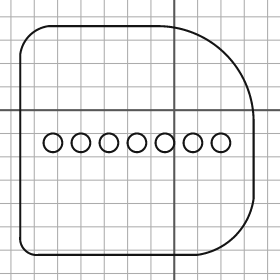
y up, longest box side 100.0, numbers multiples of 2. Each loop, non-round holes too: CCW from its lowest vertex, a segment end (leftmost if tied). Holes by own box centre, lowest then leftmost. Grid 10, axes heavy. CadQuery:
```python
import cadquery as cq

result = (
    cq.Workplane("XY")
    .moveTo(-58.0, -62.0)
    .lineTo(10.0, -62.0)
    .threePointArc((26.0, -54.0), (34.0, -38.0))
    .lineTo(34.0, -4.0)
    .threePointArc((22.0, 24.0), (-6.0, 36.0))
    .lineTo(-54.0, 36.0)
    .threePointArc((-62.0, 32.0), (-66.0, 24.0))
    .lineTo(-66.0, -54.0)
    .threePointArc((-64.0, -60.0), (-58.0, -62.0))
    .close()
    .moveTo(-52.0, -14.0)
    .circle(4.0)
    .moveTo(-40.0, -14.0)
    .circle(4.0)
    .moveTo(-28.0, -14.0)
    .circle(4.0)
    .moveTo(-16.0, -14.0)
    .circle(4.0)
    .moveTo(-4.0, -14.0)
    .circle(4.0)
    .moveTo(8.0, -14.0)
    .circle(4.0)
    .moveTo(20.0, -14.0)
    .circle(4.0)
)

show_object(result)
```